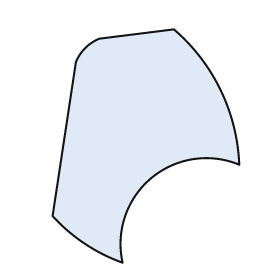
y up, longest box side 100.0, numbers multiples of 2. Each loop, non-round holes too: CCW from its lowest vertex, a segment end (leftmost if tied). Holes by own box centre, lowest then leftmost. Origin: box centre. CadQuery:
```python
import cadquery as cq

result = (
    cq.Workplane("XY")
    .moveTo(-10.0, -50.0)
    .threePointArc((2.0, -14.0), (40.0, -8.0))
    .threePointArc((32.0, 24.0), (12.0, 50.0))
    .lineTo(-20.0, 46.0)
    .threePointArc((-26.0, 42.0), (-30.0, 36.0))
    .lineTo(-40.0, -30.0)
    .threePointArc((-26.0, -42.0), (-10.0, -50.0))
    .close()
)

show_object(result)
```